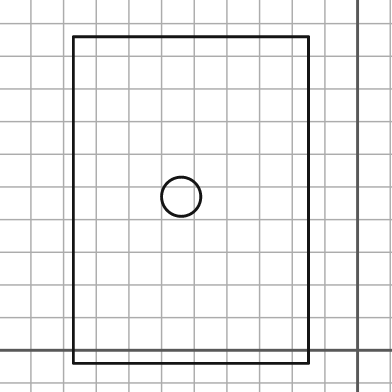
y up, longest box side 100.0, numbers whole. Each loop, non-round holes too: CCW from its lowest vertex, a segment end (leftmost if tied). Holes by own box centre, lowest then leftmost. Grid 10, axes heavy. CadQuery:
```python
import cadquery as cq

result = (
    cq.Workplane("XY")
    .moveTo(-87.0, -4.0)
    .lineTo(-15.0, -4.0)
    .lineTo(-15.0, 96.0)
    .lineTo(-87.0, 96.0)
    .close()
    .moveTo(-54.0, 47.0)
    .circle(6.0)
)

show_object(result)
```